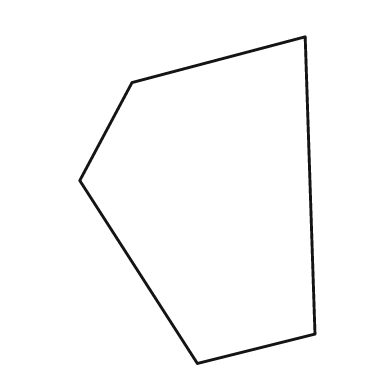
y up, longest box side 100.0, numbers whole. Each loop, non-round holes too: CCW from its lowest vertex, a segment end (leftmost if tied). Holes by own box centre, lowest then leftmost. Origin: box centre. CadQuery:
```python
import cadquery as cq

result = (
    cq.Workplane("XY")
    .moveTo(0.0, -50.0)
    .lineTo(36.0, -41.0)
    .lineTo(33.0, 50.0)
    .lineTo(-20.0, 36.0)
    .lineTo(-36.0, 6.0)
    .close()
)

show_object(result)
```